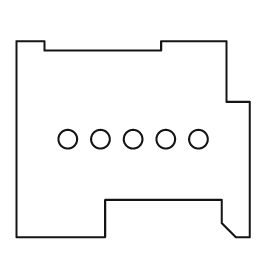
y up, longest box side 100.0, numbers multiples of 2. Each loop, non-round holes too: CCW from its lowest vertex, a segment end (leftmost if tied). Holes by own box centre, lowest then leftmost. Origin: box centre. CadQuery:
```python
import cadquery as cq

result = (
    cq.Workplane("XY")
    .moveTo(-50.0, -42.0)
    .lineTo(-12.0, -42.0)
    .lineTo(-12.0, -26.0)
    .lineTo(38.0, -26.0)
    .lineTo(38.0, -36.0)
    .lineTo(44.0, -42.0)
    .lineTo(50.0, -42.0)
    .lineTo(50.0, 16.0)
    .lineTo(40.0, 16.0)
    .lineTo(40.0, 42.0)
    .lineTo(12.0, 42.0)
    .lineTo(12.0, 38.0)
    .lineTo(-38.0, 38.0)
    .lineTo(-38.0, 42.0)
    .lineTo(-50.0, 42.0)
    .close()
    .moveTo(-28.0, 0.0)
    .circle(4.0)
    .moveTo(-14.0, 0.0)
    .circle(4.0)
    .moveTo(0.0, 0.0)
    .circle(4.0)
    .moveTo(14.0, 0.0)
    .circle(4.0)
    .moveTo(28.0, 0.0)
    .circle(4.0)
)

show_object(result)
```